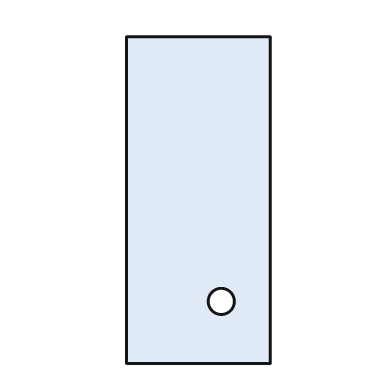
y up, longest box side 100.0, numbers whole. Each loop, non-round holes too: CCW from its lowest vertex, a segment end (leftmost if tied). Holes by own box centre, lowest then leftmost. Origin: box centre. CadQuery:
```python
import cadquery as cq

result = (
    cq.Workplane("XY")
    .moveTo(-22.0, -50.0)
    .lineTo(22.0, -50.0)
    .lineTo(22.0, 50.0)
    .lineTo(-22.0, 50.0)
    .close()
    .moveTo(7.0, -31.0)
    .circle(4.0)
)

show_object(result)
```